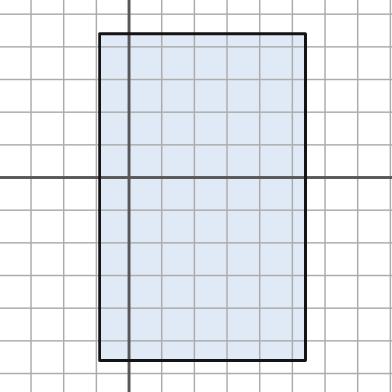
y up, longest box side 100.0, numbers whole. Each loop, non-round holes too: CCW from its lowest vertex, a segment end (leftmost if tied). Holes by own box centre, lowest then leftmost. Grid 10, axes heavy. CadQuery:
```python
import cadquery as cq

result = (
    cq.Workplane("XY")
    .moveTo(-9.0, -56.0)
    .lineTo(54.0, -56.0)
    .lineTo(54.0, 44.0)
    .lineTo(-9.0, 44.0)
    .close()
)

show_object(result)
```